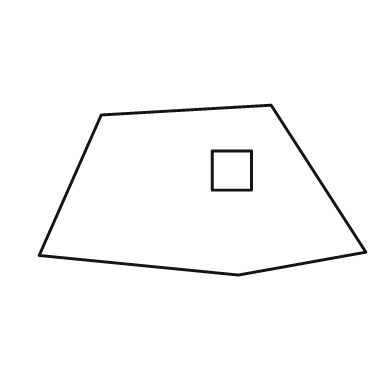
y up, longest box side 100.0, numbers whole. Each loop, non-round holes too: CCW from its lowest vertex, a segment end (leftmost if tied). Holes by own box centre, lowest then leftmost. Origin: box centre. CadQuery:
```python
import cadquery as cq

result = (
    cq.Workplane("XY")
    .moveTo(11.0, -26.0)
    .lineTo(50.0, -19.0)
    .lineTo(21.0, 26.0)
    .lineTo(-31.0, 23.0)
    .lineTo(-50.0, -20.0)
    .close()
    .moveTo(3.0, 0.0)
    .lineTo(15.0, 0.0)
    .lineTo(15.0, 12.0)
    .lineTo(3.0, 12.0)
    .close()
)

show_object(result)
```